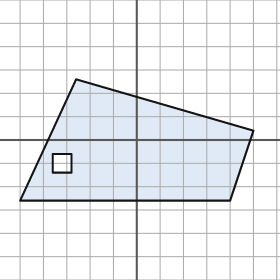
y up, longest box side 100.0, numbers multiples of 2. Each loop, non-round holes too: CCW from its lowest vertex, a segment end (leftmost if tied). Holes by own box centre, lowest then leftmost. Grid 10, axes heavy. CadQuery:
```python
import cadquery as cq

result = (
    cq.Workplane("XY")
    .moveTo(-50.0, -26.0)
    .lineTo(40.0, -26.0)
    .lineTo(50.0, 4.0)
    .lineTo(-26.0, 26.0)
    .close()
    .moveTo(-36.0, -14.0)
    .lineTo(-28.0, -14.0)
    .lineTo(-28.0, -6.0)
    .lineTo(-36.0, -6.0)
    .close()
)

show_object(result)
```